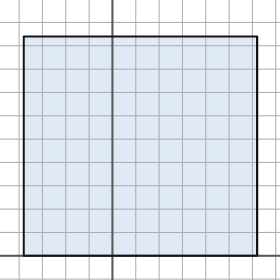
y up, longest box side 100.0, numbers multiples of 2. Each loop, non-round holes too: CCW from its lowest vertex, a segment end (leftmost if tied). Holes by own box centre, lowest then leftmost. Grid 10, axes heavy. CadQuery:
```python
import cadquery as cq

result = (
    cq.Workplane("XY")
    .moveTo(-38.0, 0.0)
    .lineTo(62.0, 0.0)
    .lineTo(62.0, 94.0)
    .lineTo(-38.0, 94.0)
    .close()
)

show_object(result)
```